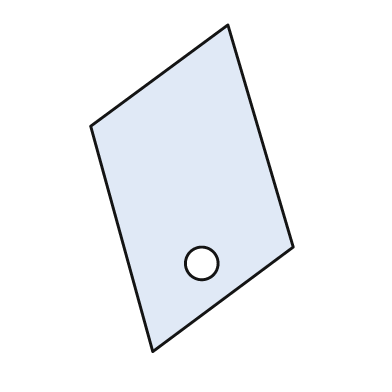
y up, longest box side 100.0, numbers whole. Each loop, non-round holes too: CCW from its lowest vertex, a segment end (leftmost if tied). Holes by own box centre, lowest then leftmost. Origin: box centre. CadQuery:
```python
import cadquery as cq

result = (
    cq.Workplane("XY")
    .moveTo(-12.0, -50.0)
    .lineTo(31.0, -18.0)
    .lineTo(11.0, 50.0)
    .lineTo(-31.0, 19.0)
    .close()
    .moveTo(3.0, -23.0)
    .circle(5.0)
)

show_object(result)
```